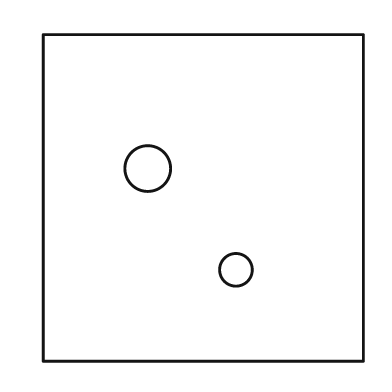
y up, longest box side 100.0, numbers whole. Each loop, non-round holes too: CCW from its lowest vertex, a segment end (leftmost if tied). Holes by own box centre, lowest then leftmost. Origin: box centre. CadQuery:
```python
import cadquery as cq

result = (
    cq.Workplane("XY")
    .moveTo(-49.0, -50.0)
    .lineTo(49.0, -50.0)
    .lineTo(49.0, 50.0)
    .lineTo(-49.0, 50.0)
    .close()
    .moveTo(10.0, -22.0)
    .circle(5.0)
    .moveTo(-17.0, 9.0)
    .circle(7.0)
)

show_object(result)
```